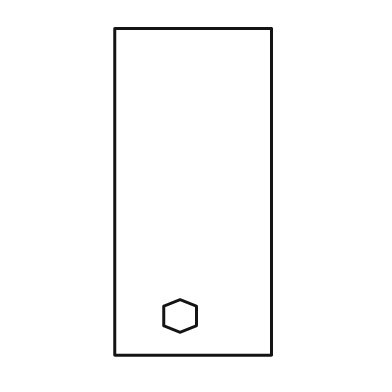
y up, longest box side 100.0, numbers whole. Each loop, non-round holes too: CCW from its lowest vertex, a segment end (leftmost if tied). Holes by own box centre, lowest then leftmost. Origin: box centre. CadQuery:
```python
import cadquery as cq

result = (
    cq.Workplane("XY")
    .moveTo(-24.0, -50.0)
    .lineTo(24.0, -50.0)
    .lineTo(24.0, 50.0)
    .lineTo(-24.0, 50.0)
    .close()
    .moveTo(-4.0, -43.0)
    .lineTo(1.0, -41.0)
    .lineTo(1.0, -35.0)
    .lineTo(-4.0, -33.0)
    .lineTo(-9.0, -35.0)
    .lineTo(-9.0, -41.0)
    .close()
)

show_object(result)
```